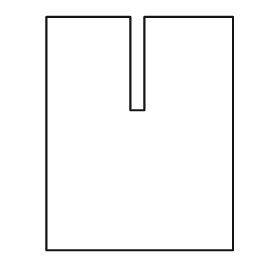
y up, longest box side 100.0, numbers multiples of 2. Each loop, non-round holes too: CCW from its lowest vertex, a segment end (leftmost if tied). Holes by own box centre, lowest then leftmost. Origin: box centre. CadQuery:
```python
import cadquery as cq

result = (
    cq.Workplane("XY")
    .moveTo(-40.0, -50.0)
    .lineTo(40.0, -50.0)
    .lineTo(40.0, 50.0)
    .lineTo(2.0, 50.0)
    .lineTo(2.0, 10.0)
    .lineTo(-4.0, 10.0)
    .lineTo(-4.0, 50.0)
    .lineTo(-40.0, 50.0)
    .close()
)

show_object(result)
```